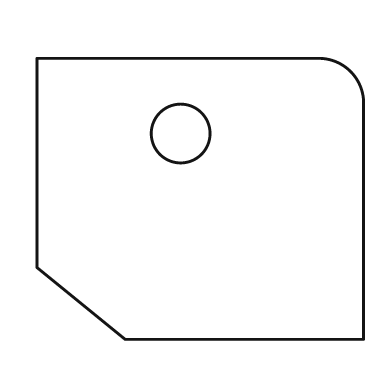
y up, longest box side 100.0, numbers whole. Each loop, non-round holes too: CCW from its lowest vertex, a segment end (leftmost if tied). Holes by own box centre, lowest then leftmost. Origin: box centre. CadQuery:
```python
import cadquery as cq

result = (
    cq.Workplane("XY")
    .moveTo(-23.0, -43.0)
    .lineTo(50.0, -43.0)
    .lineTo(50.0, 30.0)
    .threePointArc((46.0, 39.0), (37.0, 43.0))
    .lineTo(-50.0, 43.0)
    .lineTo(-50.0, -21.0)
    .close()
    .moveTo(-6.0, 20.0)
    .circle(9.0)
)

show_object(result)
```